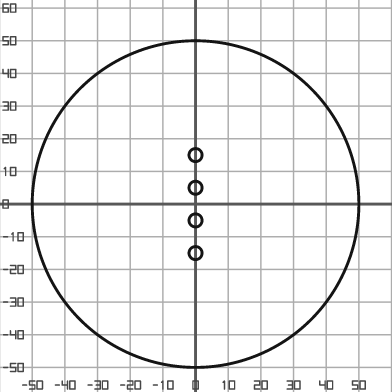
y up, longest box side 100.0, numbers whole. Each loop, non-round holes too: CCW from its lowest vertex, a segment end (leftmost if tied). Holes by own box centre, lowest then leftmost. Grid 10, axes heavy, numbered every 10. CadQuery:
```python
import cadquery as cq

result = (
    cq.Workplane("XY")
    .moveTo(0.0, 0.0)
    .circle(50.0)
    .moveTo(0.0, -15.0)
    .circle(2.0)
    .moveTo(0.0, -5.0)
    .circle(2.0)
    .moveTo(0.0, 5.0)
    .circle(2.0)
    .moveTo(0.0, 15.0)
    .circle(2.0)
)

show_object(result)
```